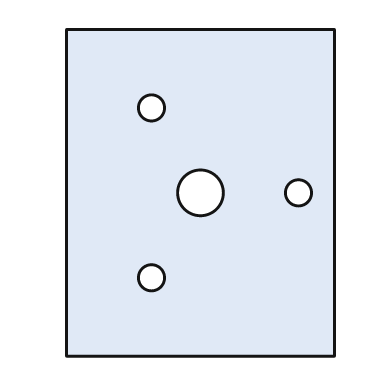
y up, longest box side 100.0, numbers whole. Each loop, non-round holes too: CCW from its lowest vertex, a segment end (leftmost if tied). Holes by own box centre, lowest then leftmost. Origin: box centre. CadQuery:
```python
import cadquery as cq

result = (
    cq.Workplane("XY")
    .moveTo(-41.0, -50.0)
    .lineTo(41.0, -50.0)
    .lineTo(41.0, 50.0)
    .lineTo(-41.0, 50.0)
    .close()
    .moveTo(-15.0, -26.0)
    .circle(4.0)
    .moveTo(0.0, 0.0)
    .circle(7.0)
    .moveTo(30.0, 0.0)
    .circle(4.0)
    .moveTo(-15.0, 26.0)
    .circle(4.0)
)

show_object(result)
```